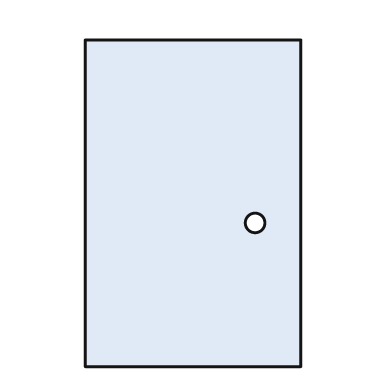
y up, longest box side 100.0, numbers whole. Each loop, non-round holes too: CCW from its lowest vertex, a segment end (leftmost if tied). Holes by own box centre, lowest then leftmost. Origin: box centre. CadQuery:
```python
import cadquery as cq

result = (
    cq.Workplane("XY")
    .moveTo(-33.0, -50.0)
    .lineTo(33.0, -50.0)
    .lineTo(33.0, 50.0)
    .lineTo(-33.0, 50.0)
    .close()
    .moveTo(19.0, -6.0)
    .circle(3.0)
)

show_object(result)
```